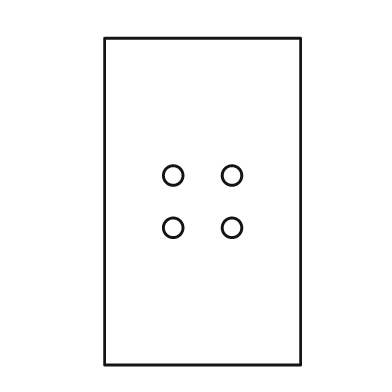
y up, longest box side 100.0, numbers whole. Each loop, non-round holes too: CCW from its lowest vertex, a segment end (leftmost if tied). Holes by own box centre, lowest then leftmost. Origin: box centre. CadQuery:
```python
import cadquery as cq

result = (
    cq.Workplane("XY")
    .moveTo(-30.0, -50.0)
    .lineTo(30.0, -50.0)
    .lineTo(30.0, 50.0)
    .lineTo(-30.0, 50.0)
    .close()
    .moveTo(-9.0, -8.0)
    .circle(3.0)
    .moveTo(9.0, -8.0)
    .circle(3.0)
    .moveTo(-9.0, 8.0)
    .circle(3.0)
    .moveTo(9.0, 8.0)
    .circle(3.0)
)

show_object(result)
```